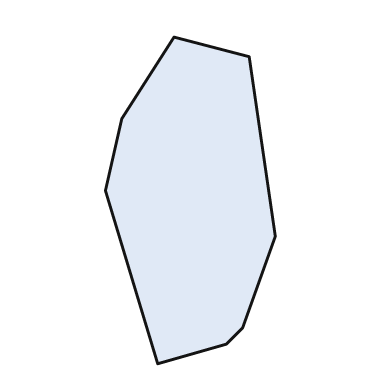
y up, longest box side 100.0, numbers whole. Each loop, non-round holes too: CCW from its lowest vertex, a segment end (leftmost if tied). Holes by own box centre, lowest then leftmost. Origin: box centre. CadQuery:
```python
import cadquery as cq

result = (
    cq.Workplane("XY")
    .moveTo(-10.0, -50.0)
    .lineTo(11.0, -44.0)
    .lineTo(16.0, -39.0)
    .lineTo(26.0, -11.0)
    .lineTo(18.0, 44.0)
    .lineTo(-5.0, 50.0)
    .lineTo(-21.0, 25.0)
    .lineTo(-26.0, 3.0)
    .close()
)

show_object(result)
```